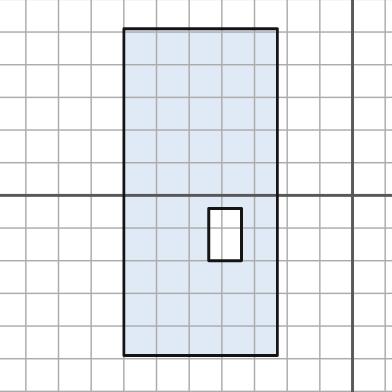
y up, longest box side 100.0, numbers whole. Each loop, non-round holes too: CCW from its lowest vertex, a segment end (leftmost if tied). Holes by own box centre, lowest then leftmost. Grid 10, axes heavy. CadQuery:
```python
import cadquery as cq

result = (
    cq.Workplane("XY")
    .moveTo(-70.0, -49.0)
    .lineTo(-23.0, -49.0)
    .lineTo(-23.0, 51.0)
    .lineTo(-70.0, 51.0)
    .close()
    .moveTo(-44.0, -20.0)
    .lineTo(-34.0, -20.0)
    .lineTo(-34.0, -4.0)
    .lineTo(-44.0, -4.0)
    .close()
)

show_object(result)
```